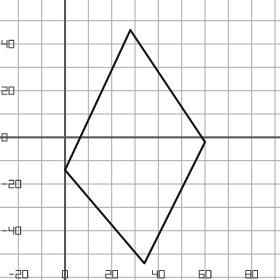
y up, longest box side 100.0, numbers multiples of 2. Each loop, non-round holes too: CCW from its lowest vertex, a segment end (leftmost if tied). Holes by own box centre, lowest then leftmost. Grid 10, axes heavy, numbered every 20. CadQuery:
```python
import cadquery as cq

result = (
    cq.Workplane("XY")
    .moveTo(34.0, -54.0)
    .lineTo(60.0, -2.0)
    .lineTo(28.0, 46.0)
    .lineTo(0.0, -14.0)
    .close()
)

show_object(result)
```